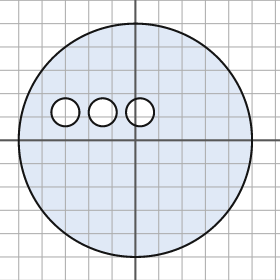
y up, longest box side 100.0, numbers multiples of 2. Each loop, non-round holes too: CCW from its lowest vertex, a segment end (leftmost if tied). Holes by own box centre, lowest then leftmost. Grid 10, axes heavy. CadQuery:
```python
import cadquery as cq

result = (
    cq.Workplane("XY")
    .moveTo(0.0, 0.0)
    .circle(50.0)
    .moveTo(-30.0, 12.0)
    .circle(6.0)
    .moveTo(-14.0, 12.0)
    .circle(6.0)
    .moveTo(2.0, 12.0)
    .circle(6.0)
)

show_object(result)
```